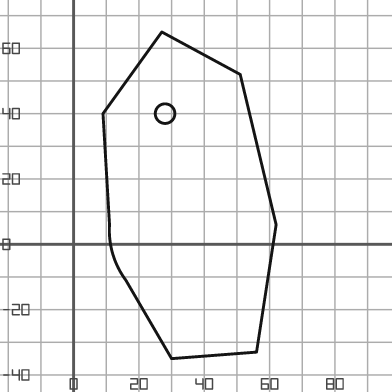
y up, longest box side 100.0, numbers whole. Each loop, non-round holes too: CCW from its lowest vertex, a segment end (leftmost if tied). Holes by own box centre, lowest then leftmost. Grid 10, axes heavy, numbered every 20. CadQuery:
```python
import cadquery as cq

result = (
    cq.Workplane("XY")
    .moveTo(30.0, -35.0)
    .lineTo(56.0, -33.0)
    .lineTo(62.0, 6.0)
    .lineTo(51.0, 52.0)
    .lineTo(27.0, 65.0)
    .lineTo(9.0, 40.0)
    .lineTo(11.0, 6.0)
    .threePointArc((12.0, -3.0), (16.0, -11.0))
    .close()
    .moveTo(28.0, 40.0)
    .circle(3.0)
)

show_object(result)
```